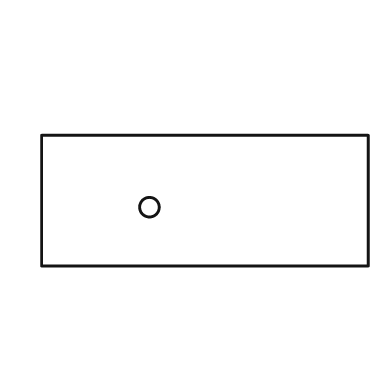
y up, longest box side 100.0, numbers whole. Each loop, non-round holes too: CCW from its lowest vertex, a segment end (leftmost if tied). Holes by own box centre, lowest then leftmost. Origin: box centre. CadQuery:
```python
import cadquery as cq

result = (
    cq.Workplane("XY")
    .moveTo(-50.0, -20.0)
    .lineTo(50.0, -20.0)
    .lineTo(50.0, 20.0)
    .lineTo(-50.0, 20.0)
    .close()
    .moveTo(-17.0, -2.0)
    .circle(3.0)
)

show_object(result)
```